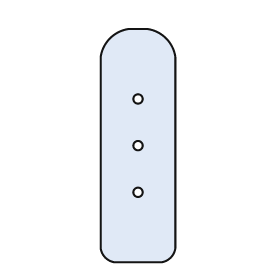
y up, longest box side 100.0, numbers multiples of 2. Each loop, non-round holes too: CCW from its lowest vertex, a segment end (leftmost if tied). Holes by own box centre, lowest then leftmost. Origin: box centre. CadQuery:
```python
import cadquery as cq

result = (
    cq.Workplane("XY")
    .moveTo(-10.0, -50.0)
    .lineTo(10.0, -50.0)
    .threePointArc((14.0, -48.0), (16.0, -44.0))
    .lineTo(16.0, 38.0)
    .threePointArc((12.0, 46.0), (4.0, 50.0))
    .lineTo(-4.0, 50.0)
    .threePointArc((-12.0, 46.0), (-16.0, 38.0))
    .lineTo(-16.0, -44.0)
    .threePointArc((-14.0, -48.0), (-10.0, -50.0))
    .close()
    .moveTo(0.0, -20.0)
    .circle(2.0)
    .moveTo(0.0, 0.0)
    .circle(2.0)
    .moveTo(0.0, 20.0)
    .circle(2.0)
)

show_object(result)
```